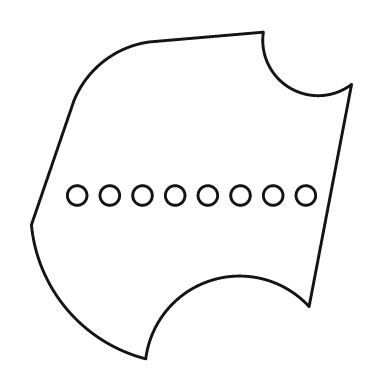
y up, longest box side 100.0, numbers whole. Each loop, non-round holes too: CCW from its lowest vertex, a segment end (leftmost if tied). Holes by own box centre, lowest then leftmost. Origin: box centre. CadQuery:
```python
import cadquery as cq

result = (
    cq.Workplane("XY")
    .moveTo(-14.0, -50.0)
    .threePointArc((6.0, -26.0), (36.0, -34.0))
    .lineTo(49.0, 34.0)
    .threePointArc((30.0, 33.0), (22.0, 50.0))
    .lineTo(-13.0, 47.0)
    .threePointArc((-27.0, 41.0), (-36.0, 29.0))
    .lineTo(-49.0, -9.0)
    .threePointArc((-38.0, -35.0), (-14.0, -50.0))
    .close()
    .moveTo(-35.0, 0.0)
    .circle(3.0)
    .moveTo(-25.0, 0.0)
    .circle(3.0)
    .moveTo(-15.0, 0.0)
    .circle(3.0)
    .moveTo(-5.0, 0.0)
    .circle(3.0)
    .moveTo(5.0, 0.0)
    .circle(3.0)
    .moveTo(15.0, 0.0)
    .circle(3.0)
    .moveTo(25.0, 0.0)
    .circle(3.0)
    .moveTo(35.0, 0.0)
    .circle(3.0)
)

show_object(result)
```